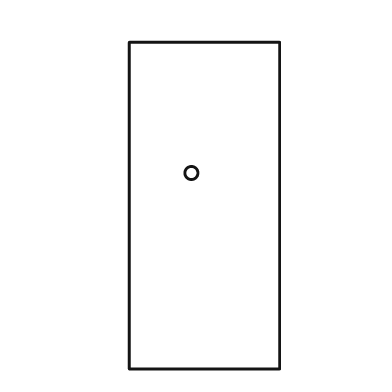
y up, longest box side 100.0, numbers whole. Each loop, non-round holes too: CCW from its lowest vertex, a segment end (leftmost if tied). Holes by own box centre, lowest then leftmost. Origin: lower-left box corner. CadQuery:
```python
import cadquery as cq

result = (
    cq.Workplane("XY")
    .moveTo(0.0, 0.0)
    .lineTo(46.0, 0.0)
    .lineTo(46.0, 100.0)
    .lineTo(0.0, 100.0)
    .close()
    .moveTo(19.0, 60.0)
    .circle(2.0)
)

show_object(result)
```